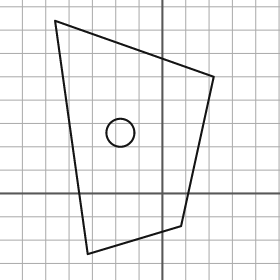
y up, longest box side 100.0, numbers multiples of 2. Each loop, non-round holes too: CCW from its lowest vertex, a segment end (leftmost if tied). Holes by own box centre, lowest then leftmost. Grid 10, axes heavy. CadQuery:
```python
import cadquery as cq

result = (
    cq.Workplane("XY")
    .moveTo(-32.0, -26.0)
    .lineTo(8.0, -14.0)
    .lineTo(22.0, 50.0)
    .lineTo(-46.0, 74.0)
    .close()
    .moveTo(-18.0, 26.0)
    .circle(6.0)
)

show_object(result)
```